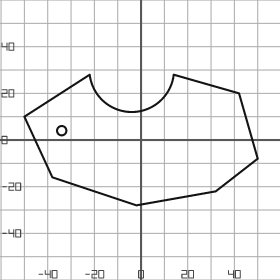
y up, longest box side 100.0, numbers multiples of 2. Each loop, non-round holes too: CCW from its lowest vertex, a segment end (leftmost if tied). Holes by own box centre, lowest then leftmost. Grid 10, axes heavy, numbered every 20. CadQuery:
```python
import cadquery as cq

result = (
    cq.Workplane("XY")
    .moveTo(-2.0, -28.0)
    .lineTo(32.0, -22.0)
    .lineTo(50.0, -8.0)
    .lineTo(42.0, 20.0)
    .lineTo(14.0, 28.0)
    .threePointArc((-4.0, 12.0), (-22.0, 28.0))
    .lineTo(-50.0, 10.0)
    .lineTo(-38.0, -16.0)
    .close()
    .moveTo(-34.0, 4.0)
    .circle(2.0)
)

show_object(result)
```